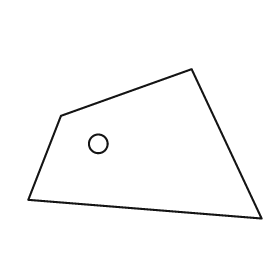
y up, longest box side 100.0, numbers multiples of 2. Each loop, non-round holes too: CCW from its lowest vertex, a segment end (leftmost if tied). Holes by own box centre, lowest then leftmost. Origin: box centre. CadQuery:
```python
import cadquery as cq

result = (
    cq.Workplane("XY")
    .moveTo(50.0, -32.0)
    .lineTo(20.0, 32.0)
    .lineTo(-36.0, 12.0)
    .lineTo(-50.0, -24.0)
    .close()
    .moveTo(-20.0, 0.0)
    .circle(4.0)
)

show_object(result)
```